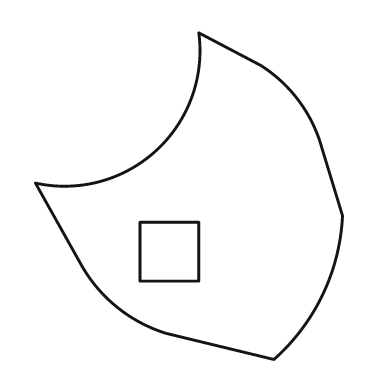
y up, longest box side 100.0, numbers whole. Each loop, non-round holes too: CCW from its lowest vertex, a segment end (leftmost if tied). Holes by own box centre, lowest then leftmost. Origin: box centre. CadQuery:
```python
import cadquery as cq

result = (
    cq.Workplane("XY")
    .moveTo(26.0, -50.0)
    .threePointArc((41.0, -30.0), (47.0, -6.0))
    .lineTo(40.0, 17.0)
    .threePointArc((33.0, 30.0), (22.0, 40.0))
    .lineTo(3.0, 50.0)
    .threePointArc((-10.0, 14.0), (-47.0, 4.0))
    .lineTo(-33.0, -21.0)
    .threePointArc((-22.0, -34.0), (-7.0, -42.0))
    .close()
    .moveTo(-15.0, -26.0)
    .lineTo(3.0, -26.0)
    .lineTo(3.0, -8.0)
    .lineTo(-15.0, -8.0)
    .close()
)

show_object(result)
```